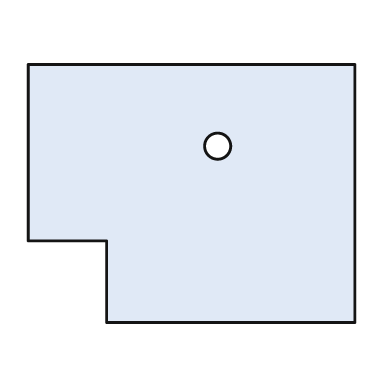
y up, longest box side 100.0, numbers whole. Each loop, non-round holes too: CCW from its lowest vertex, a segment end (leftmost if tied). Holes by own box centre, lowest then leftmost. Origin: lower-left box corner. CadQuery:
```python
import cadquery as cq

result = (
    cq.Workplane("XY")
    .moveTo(24.0, 0.0)
    .lineTo(100.0, 0.0)
    .lineTo(100.0, 79.0)
    .lineTo(0.0, 79.0)
    .lineTo(0.0, 25.0)
    .lineTo(24.0, 25.0)
    .close()
    .moveTo(58.0, 54.0)
    .circle(4.0)
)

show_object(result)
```